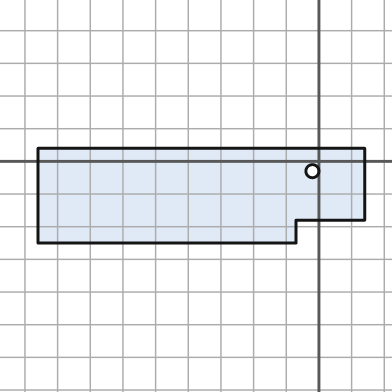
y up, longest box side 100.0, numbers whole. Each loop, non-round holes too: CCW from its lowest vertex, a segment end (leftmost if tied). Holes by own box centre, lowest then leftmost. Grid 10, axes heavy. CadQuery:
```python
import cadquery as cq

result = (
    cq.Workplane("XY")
    .moveTo(-86.0, -25.0)
    .lineTo(-7.0, -25.0)
    .lineTo(-7.0, -18.0)
    .lineTo(14.0, -18.0)
    .lineTo(14.0, 4.0)
    .lineTo(-86.0, 4.0)
    .close()
    .moveTo(-2.0, -3.0)
    .circle(2.0)
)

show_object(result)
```